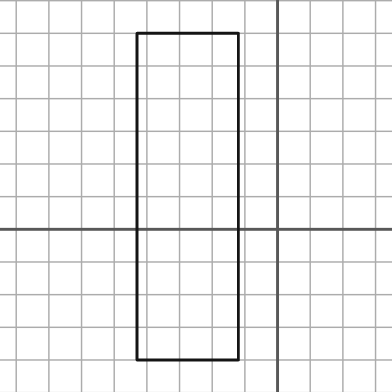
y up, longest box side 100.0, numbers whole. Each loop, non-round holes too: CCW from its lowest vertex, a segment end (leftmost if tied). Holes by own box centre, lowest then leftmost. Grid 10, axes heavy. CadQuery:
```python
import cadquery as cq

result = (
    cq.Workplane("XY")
    .moveTo(-43.0, -40.0)
    .lineTo(-12.0, -40.0)
    .lineTo(-12.0, 60.0)
    .lineTo(-43.0, 60.0)
    .close()
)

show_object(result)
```